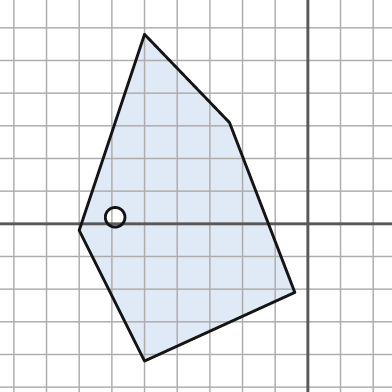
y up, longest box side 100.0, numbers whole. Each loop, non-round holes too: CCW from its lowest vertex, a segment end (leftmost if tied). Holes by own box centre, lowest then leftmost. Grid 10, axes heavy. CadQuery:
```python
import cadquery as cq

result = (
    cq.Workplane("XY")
    .moveTo(-50.0, -42.0)
    .lineTo(-4.0, -21.0)
    .lineTo(-24.0, 31.0)
    .lineTo(-50.0, 58.0)
    .lineTo(-70.0, -2.0)
    .close()
    .moveTo(-59.0, 2.0)
    .circle(3.0)
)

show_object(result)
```